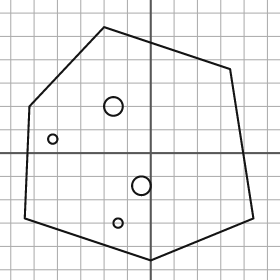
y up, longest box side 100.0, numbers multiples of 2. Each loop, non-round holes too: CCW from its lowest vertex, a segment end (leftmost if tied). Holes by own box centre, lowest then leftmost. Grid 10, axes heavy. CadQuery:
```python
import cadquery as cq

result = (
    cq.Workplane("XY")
    .moveTo(0.0, -46.0)
    .lineTo(44.0, -28.0)
    .lineTo(34.0, 36.0)
    .lineTo(-20.0, 54.0)
    .lineTo(-52.0, 20.0)
    .lineTo(-54.0, -28.0)
    .close()
    .moveTo(-14.0, -30.0)
    .circle(2.0)
    .moveTo(-4.0, -14.0)
    .circle(4.0)
    .moveTo(-42.0, 6.0)
    .circle(2.0)
    .moveTo(-16.0, 20.0)
    .circle(4.0)
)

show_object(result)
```